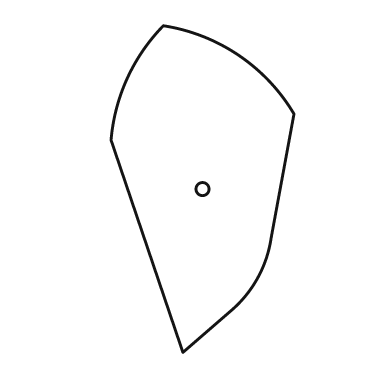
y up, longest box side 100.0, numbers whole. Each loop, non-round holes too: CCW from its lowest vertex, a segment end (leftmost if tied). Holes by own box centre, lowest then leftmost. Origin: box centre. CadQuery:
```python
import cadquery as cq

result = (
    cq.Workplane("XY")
    .moveTo(-6.0, -50.0)
    .lineTo(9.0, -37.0)
    .threePointArc((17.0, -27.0), (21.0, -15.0))
    .lineTo(28.0, 23.0)
    .threePointArc((11.0, 41.0), (-12.0, 50.0))
    .threePointArc((-23.0, 34.0), (-28.0, 15.0))
    .close()
    .moveTo(0.0, 0.0)
    .circle(2.0)
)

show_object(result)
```